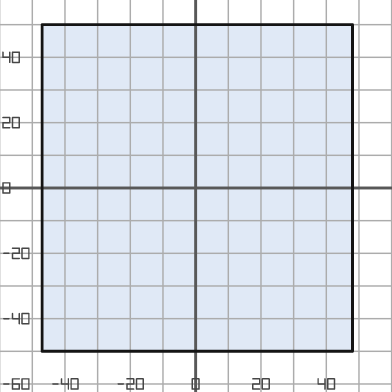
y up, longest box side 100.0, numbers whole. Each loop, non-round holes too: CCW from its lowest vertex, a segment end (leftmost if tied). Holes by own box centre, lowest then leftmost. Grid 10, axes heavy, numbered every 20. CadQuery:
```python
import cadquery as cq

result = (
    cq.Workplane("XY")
    .moveTo(-47.0, -50.0)
    .lineTo(48.0, -50.0)
    .lineTo(48.0, 50.0)
    .lineTo(-47.0, 50.0)
    .close()
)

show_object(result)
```